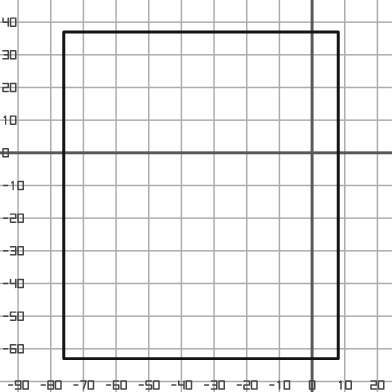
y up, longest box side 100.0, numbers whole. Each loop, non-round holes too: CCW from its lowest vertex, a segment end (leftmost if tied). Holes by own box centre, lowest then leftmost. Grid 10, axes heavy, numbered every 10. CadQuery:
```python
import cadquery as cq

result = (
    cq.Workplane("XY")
    .moveTo(-76.0, -63.0)
    .lineTo(8.0, -63.0)
    .lineTo(8.0, 37.0)
    .lineTo(-76.0, 37.0)
    .close()
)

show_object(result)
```